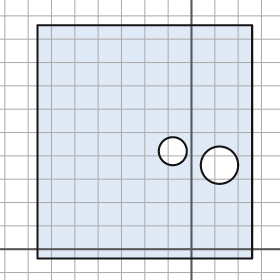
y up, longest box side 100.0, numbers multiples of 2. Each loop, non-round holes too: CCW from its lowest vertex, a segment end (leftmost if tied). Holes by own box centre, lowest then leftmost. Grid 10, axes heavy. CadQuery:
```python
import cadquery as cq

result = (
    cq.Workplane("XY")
    .moveTo(-66.0, -4.0)
    .lineTo(26.0, -4.0)
    .lineTo(26.0, 96.0)
    .lineTo(-66.0, 96.0)
    .close()
    .moveTo(12.0, 36.0)
    .circle(8.0)
    .moveTo(-8.0, 42.0)
    .circle(6.0)
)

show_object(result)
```